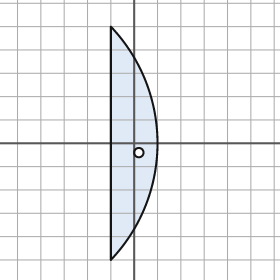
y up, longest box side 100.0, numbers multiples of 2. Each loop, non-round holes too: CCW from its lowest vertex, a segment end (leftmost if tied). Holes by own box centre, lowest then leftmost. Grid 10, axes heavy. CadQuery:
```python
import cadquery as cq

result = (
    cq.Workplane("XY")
    .moveTo(-10.0, -50.0)
    .threePointArc((10.0, 0.0), (-10.0, 50.0))
    .close()
    .moveTo(2.0, -4.0)
    .circle(2.0)
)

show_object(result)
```